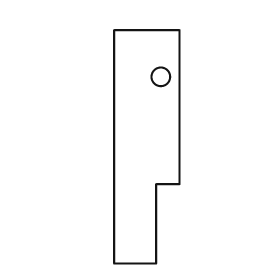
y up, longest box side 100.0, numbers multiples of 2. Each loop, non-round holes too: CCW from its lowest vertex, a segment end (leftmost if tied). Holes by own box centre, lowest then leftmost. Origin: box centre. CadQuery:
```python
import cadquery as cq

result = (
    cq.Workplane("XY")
    .moveTo(-14.0, -50.0)
    .lineTo(4.0, -50.0)
    .lineTo(4.0, -16.0)
    .lineTo(14.0, -16.0)
    .lineTo(14.0, 50.0)
    .lineTo(-14.0, 50.0)
    .close()
    .moveTo(6.0, 30.0)
    .circle(4.0)
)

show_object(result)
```